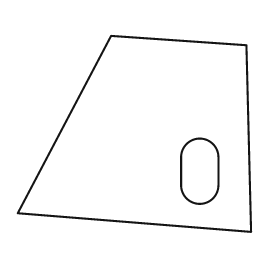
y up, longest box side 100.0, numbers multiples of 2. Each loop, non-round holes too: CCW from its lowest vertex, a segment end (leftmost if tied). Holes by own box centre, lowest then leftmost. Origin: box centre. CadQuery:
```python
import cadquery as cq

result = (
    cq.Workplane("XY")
    .moveTo(50.0, -42.0)
    .lineTo(48.0, 38.0)
    .lineTo(-10.0, 42.0)
    .lineTo(-50.0, -34.0)
    .close()
    .moveTo(20.0, -22.0)
    .threePointArc((28.0, -30.0), (36.0, -22.0))
    .lineTo(36.0, -10.0)
    .threePointArc((28.0, -2.0), (20.0, -10.0))
    .close()
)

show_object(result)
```